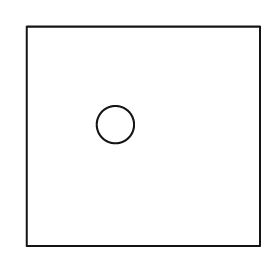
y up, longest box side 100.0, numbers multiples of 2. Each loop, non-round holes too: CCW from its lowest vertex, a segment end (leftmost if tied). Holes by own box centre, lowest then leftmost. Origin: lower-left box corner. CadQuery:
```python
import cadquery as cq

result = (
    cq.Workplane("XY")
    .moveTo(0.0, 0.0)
    .lineTo(100.0, 0.0)
    .lineTo(100.0, 94.0)
    .lineTo(0.0, 94.0)
    .close()
    .moveTo(38.0, 52.0)
    .circle(8.0)
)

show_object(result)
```